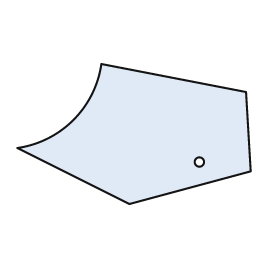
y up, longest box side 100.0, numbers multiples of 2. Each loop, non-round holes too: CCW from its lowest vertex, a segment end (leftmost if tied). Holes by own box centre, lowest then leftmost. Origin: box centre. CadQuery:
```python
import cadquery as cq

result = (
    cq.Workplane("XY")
    .moveTo(-2.0, -30.0)
    .lineTo(50.0, -16.0)
    .lineTo(48.0, 18.0)
    .lineTo(-14.0, 30.0)
    .threePointArc((-26.0, 6.0), (-50.0, -6.0))
    .close()
    .moveTo(28.0, -12.0)
    .circle(2.0)
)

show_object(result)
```